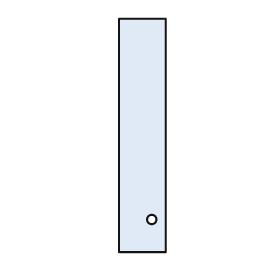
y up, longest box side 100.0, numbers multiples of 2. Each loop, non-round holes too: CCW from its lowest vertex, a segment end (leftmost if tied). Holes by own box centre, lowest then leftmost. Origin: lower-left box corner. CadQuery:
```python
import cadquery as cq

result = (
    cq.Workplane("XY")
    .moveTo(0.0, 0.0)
    .lineTo(20.0, 0.0)
    .lineTo(20.0, 100.0)
    .lineTo(0.0, 100.0)
    .close()
    .moveTo(14.0, 14.0)
    .circle(2.0)
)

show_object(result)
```